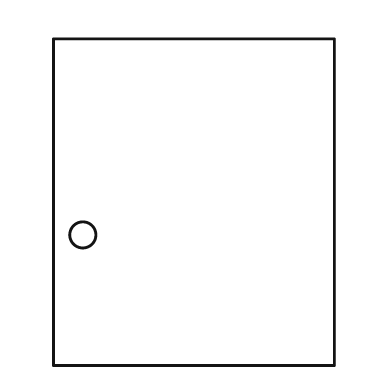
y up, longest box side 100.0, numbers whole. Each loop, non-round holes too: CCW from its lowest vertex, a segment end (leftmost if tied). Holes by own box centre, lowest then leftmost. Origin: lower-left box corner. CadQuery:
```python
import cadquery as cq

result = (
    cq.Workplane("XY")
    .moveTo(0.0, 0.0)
    .lineTo(86.0, 0.0)
    .lineTo(86.0, 100.0)
    .lineTo(0.0, 100.0)
    .close()
    .moveTo(9.0, 40.0)
    .circle(4.0)
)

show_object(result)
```